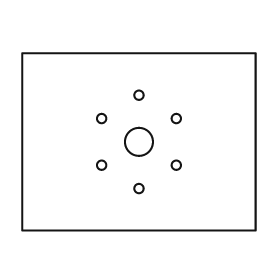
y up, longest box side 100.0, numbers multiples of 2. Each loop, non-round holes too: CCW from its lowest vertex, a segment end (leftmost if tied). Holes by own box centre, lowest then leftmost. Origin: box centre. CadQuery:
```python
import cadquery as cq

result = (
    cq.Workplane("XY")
    .moveTo(-50.0, -38.0)
    .lineTo(50.0, -38.0)
    .lineTo(50.0, 38.0)
    .lineTo(-50.0, 38.0)
    .close()
    .moveTo(0.0, -20.0)
    .circle(2.0)
    .moveTo(-16.0, -10.0)
    .circle(2.0)
    .moveTo(16.0, -10.0)
    .circle(2.0)
    .moveTo(0.0, 0.0)
    .circle(6.0)
    .moveTo(-16.0, 10.0)
    .circle(2.0)
    .moveTo(16.0, 10.0)
    .circle(2.0)
    .moveTo(0.0, 20.0)
    .circle(2.0)
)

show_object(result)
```